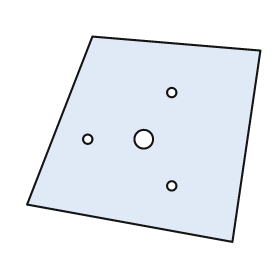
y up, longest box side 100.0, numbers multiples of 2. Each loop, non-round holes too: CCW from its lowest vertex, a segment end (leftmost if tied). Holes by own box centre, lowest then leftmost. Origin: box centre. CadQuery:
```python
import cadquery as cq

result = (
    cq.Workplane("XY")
    .moveTo(38.0, -44.0)
    .lineTo(50.0, 38.0)
    .lineTo(-22.0, 44.0)
    .lineTo(-50.0, -28.0)
    .close()
    .moveTo(12.0, -20.0)
    .circle(2.0)
    .moveTo(-24.0, 0.0)
    .circle(2.0)
    .moveTo(0.0, 0.0)
    .circle(4.0)
    .moveTo(12.0, 20.0)
    .circle(2.0)
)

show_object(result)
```